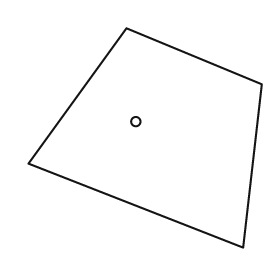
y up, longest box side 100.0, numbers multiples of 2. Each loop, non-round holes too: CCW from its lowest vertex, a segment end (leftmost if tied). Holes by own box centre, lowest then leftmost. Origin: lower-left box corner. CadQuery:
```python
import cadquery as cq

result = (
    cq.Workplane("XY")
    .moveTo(92.0, 0.0)
    .lineTo(100.0, 70.0)
    .lineTo(42.0, 94.0)
    .lineTo(0.0, 36.0)
    .close()
    .moveTo(46.0, 54.0)
    .circle(2.0)
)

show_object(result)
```